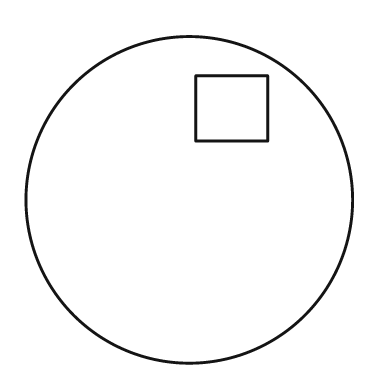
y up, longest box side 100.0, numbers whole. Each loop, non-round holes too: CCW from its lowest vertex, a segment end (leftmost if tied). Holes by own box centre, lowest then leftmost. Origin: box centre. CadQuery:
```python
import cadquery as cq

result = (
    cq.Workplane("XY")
    .moveTo(0.0, 0.0)
    .circle(50.0)
    .moveTo(2.0, 18.0)
    .lineTo(24.0, 18.0)
    .lineTo(24.0, 38.0)
    .lineTo(2.0, 38.0)
    .close()
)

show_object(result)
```